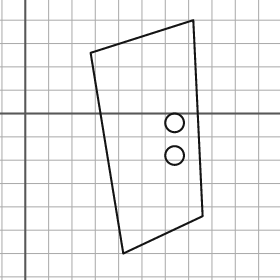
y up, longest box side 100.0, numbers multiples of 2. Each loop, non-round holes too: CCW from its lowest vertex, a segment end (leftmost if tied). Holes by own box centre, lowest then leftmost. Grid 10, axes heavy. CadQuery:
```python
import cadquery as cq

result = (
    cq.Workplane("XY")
    .moveTo(42.0, -60.0)
    .lineTo(76.0, -44.0)
    .lineTo(72.0, 40.0)
    .lineTo(28.0, 26.0)
    .close()
    .moveTo(64.0, -18.0)
    .circle(4.0)
    .moveTo(64.0, -4.0)
    .circle(4.0)
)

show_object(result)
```